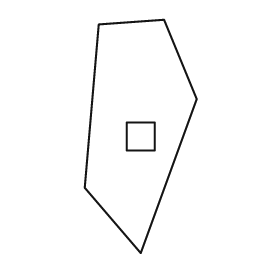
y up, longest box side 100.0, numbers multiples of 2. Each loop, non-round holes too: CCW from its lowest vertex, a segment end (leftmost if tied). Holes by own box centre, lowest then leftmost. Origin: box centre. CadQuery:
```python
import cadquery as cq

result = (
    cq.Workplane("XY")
    .moveTo(0.0, -50.0)
    .lineTo(24.0, 16.0)
    .lineTo(10.0, 50.0)
    .lineTo(-18.0, 48.0)
    .lineTo(-24.0, -22.0)
    .close()
    .moveTo(-6.0, -6.0)
    .lineTo(6.0, -6.0)
    .lineTo(6.0, 6.0)
    .lineTo(-6.0, 6.0)
    .close()
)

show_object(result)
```